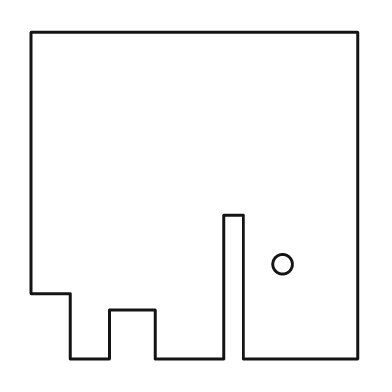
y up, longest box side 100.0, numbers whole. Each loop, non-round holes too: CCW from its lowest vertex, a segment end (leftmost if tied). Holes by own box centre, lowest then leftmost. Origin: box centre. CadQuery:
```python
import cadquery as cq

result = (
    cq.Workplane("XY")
    .moveTo(-38.0, -50.0)
    .lineTo(-26.0, -50.0)
    .lineTo(-26.0, -35.0)
    .lineTo(-12.0, -35.0)
    .lineTo(-12.0, -50.0)
    .lineTo(9.0, -50.0)
    .lineTo(9.0, -6.0)
    .lineTo(15.0, -6.0)
    .lineTo(15.0, -50.0)
    .lineTo(50.0, -50.0)
    .lineTo(50.0, 50.0)
    .lineTo(-50.0, 50.0)
    .lineTo(-50.0, -30.0)
    .lineTo(-38.0, -30.0)
    .close()
    .moveTo(27.0, -21.0)
    .circle(3.0)
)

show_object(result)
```